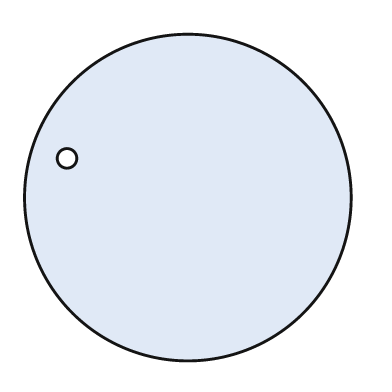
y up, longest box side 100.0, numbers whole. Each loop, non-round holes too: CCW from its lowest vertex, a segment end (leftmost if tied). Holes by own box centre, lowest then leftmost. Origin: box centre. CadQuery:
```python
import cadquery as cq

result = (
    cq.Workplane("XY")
    .moveTo(0.0, 0.0)
    .circle(50.0)
    .moveTo(-37.0, 12.0)
    .circle(3.0)
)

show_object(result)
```